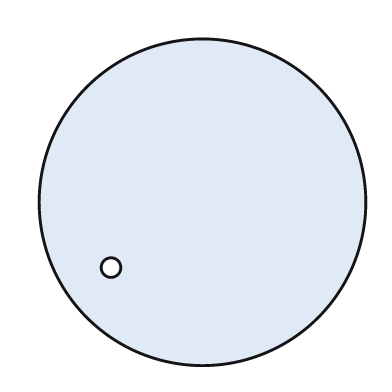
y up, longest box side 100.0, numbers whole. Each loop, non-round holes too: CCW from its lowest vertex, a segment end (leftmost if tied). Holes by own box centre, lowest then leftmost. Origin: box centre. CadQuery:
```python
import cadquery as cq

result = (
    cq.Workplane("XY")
    .moveTo(0.0, 0.0)
    .circle(50.0)
    .moveTo(-28.0, -20.0)
    .circle(3.0)
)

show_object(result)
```